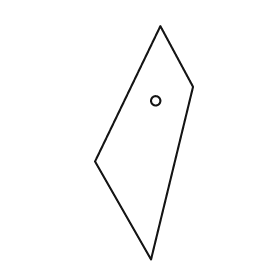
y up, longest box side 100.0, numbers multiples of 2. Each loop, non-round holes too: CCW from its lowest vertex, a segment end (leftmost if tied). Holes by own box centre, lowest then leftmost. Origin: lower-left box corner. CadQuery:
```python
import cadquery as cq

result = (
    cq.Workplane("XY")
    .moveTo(24.0, 0.0)
    .lineTo(42.0, 74.0)
    .lineTo(28.0, 100.0)
    .lineTo(0.0, 42.0)
    .close()
    .moveTo(26.0, 68.0)
    .circle(2.0)
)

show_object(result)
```